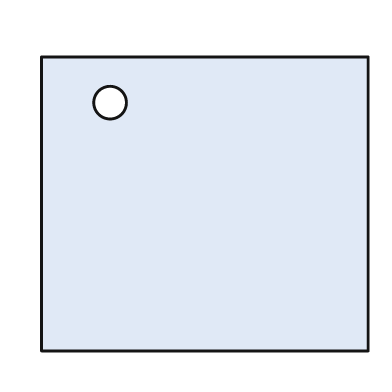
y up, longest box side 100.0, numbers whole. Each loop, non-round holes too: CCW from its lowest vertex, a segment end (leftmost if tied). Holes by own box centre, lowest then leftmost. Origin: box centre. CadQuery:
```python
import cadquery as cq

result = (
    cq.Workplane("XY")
    .moveTo(-50.0, -45.0)
    .lineTo(50.0, -45.0)
    .lineTo(50.0, 45.0)
    .lineTo(-50.0, 45.0)
    .close()
    .moveTo(-29.0, 31.0)
    .circle(5.0)
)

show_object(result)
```